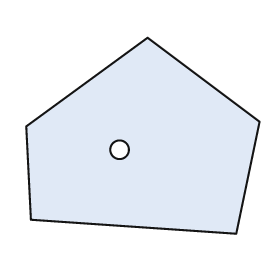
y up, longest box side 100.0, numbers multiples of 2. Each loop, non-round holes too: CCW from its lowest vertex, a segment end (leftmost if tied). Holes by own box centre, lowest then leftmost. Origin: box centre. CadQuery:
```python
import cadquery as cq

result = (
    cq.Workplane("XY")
    .moveTo(40.0, -42.0)
    .lineTo(50.0, 6.0)
    .lineTo(2.0, 42.0)
    .lineTo(-50.0, 4.0)
    .lineTo(-48.0, -36.0)
    .close()
    .moveTo(-10.0, -6.0)
    .circle(4.0)
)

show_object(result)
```